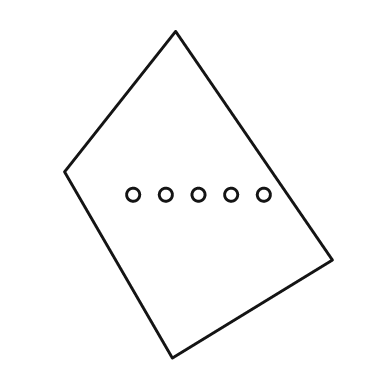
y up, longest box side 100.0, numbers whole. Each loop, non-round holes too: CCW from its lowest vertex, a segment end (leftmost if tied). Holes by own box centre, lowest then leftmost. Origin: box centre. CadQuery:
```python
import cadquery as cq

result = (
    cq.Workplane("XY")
    .moveTo(-8.0, -50.0)
    .lineTo(41.0, -20.0)
    .lineTo(-7.0, 50.0)
    .lineTo(-41.0, 7.0)
    .close()
    .moveTo(-20.0, 0.0)
    .circle(2.0)
    .moveTo(-10.0, 0.0)
    .circle(2.0)
    .moveTo(0.0, 0.0)
    .circle(2.0)
    .moveTo(10.0, 0.0)
    .circle(2.0)
    .moveTo(20.0, 0.0)
    .circle(2.0)
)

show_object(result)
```